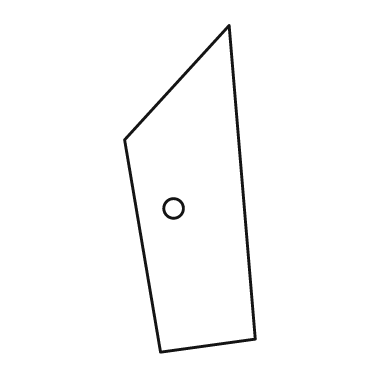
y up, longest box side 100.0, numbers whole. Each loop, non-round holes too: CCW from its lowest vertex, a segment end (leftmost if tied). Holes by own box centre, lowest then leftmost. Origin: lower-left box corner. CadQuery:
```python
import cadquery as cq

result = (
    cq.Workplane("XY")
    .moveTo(11.0, 0.0)
    .lineTo(40.0, 4.0)
    .lineTo(32.0, 100.0)
    .lineTo(0.0, 65.0)
    .close()
    .moveTo(15.0, 44.0)
    .circle(3.0)
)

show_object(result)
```